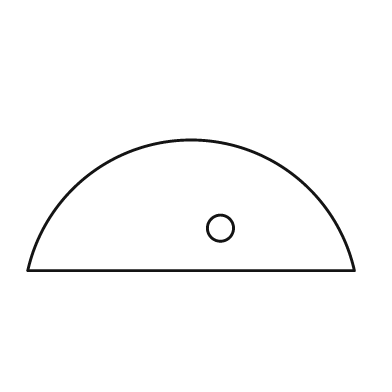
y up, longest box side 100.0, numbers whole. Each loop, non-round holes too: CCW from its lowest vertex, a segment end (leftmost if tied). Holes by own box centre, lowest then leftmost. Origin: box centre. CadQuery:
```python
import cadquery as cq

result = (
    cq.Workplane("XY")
    .moveTo(-50.0, -20.0)
    .lineTo(50.0, -20.0)
    .threePointArc((0.0, 20.0), (-50.0, -20.0))
    .close()
    .moveTo(9.0, -7.0)
    .circle(4.0)
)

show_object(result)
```